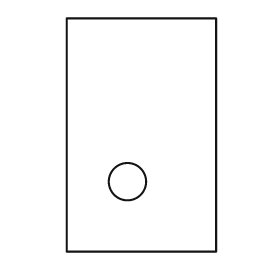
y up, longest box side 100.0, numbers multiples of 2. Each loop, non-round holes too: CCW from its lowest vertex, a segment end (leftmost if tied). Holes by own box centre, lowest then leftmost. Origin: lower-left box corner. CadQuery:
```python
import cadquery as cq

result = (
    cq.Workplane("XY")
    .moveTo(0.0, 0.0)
    .lineTo(64.0, 0.0)
    .lineTo(64.0, 100.0)
    .lineTo(0.0, 100.0)
    .close()
    .moveTo(26.0, 30.0)
    .circle(8.0)
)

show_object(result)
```